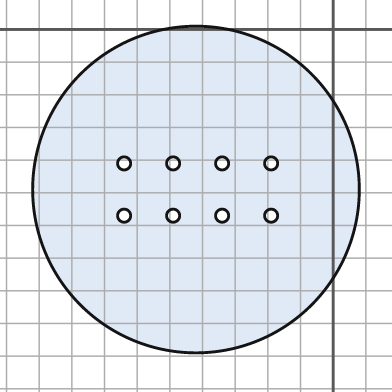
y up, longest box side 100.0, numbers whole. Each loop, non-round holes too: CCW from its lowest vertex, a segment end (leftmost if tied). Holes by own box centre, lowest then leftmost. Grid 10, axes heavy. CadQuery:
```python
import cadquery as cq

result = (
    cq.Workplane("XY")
    .moveTo(-42.0, -49.0)
    .circle(50.0)
    .moveTo(-64.0, -57.0)
    .circle(2.0)
    .moveTo(-49.0, -57.0)
    .circle(2.0)
    .moveTo(-34.0, -57.0)
    .circle(2.0)
    .moveTo(-19.0, -57.0)
    .circle(2.0)
    .moveTo(-64.0, -41.0)
    .circle(2.0)
    .moveTo(-49.0, -41.0)
    .circle(2.0)
    .moveTo(-34.0, -41.0)
    .circle(2.0)
    .moveTo(-19.0, -41.0)
    .circle(2.0)
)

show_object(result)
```